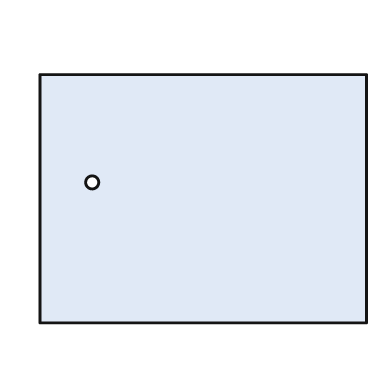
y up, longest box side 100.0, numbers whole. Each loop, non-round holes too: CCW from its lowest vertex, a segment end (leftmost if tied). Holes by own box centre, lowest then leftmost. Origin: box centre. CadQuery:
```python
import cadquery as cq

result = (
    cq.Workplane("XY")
    .moveTo(-50.0, -38.0)
    .lineTo(50.0, -38.0)
    .lineTo(50.0, 38.0)
    .lineTo(-50.0, 38.0)
    .close()
    .moveTo(-34.0, 5.0)
    .circle(2.0)
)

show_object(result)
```